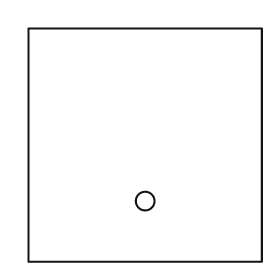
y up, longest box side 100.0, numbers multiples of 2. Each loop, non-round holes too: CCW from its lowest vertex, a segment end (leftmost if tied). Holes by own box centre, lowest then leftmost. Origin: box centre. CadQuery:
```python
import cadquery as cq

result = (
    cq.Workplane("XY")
    .moveTo(-50.0, -50.0)
    .lineTo(50.0, -50.0)
    .lineTo(50.0, 50.0)
    .lineTo(-50.0, 50.0)
    .close()
    .moveTo(0.0, -24.0)
    .circle(4.0)
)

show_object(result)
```